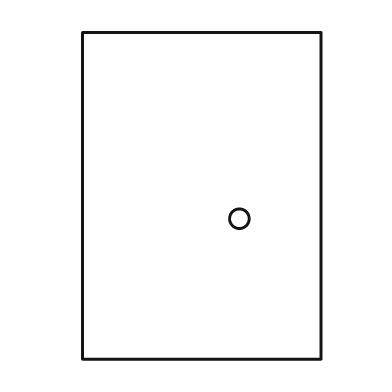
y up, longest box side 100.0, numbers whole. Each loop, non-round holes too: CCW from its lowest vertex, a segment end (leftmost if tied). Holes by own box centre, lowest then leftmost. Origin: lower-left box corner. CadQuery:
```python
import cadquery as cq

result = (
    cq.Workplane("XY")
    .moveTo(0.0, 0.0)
    .lineTo(73.0, 0.0)
    .lineTo(73.0, 100.0)
    .lineTo(0.0, 100.0)
    .close()
    .moveTo(48.0, 43.0)
    .circle(3.0)
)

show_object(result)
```